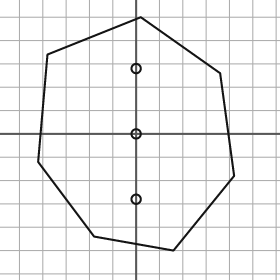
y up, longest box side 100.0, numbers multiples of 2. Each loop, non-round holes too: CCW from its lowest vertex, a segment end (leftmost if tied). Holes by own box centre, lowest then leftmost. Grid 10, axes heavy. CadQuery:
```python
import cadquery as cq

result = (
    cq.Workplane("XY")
    .moveTo(16.0, -50.0)
    .lineTo(42.0, -18.0)
    .lineTo(36.0, 26.0)
    .lineTo(2.0, 50.0)
    .lineTo(-38.0, 34.0)
    .lineTo(-42.0, -12.0)
    .lineTo(-18.0, -44.0)
    .close()
    .moveTo(0.0, -28.0)
    .circle(2.0)
    .moveTo(0.0, 0.0)
    .circle(2.0)
    .moveTo(0.0, 28.0)
    .circle(2.0)
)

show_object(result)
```